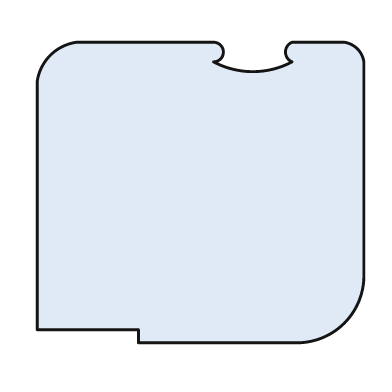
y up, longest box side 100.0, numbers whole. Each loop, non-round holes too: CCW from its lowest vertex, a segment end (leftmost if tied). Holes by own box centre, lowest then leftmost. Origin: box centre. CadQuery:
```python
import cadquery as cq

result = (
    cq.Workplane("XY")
    .moveTo(-19.0, -46.0)
    .lineTo(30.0, -46.0)
    .threePointArc((44.0, -40.0), (50.0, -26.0))
    .lineTo(50.0, 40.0)
    .threePointArc((48.0, 44.0), (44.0, 46.0))
    .lineTo(28.0, 46.0)
    .threePointArc((26.0, 43.0), (28.0, 40.0))
    .threePointArc((16.0, 37.0), (4.0, 40.0))
    .threePointArc((7.0, 43.0), (4.0, 46.0))
    .lineTo(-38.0, 46.0)
    .threePointArc((-46.0, 42.0), (-50.0, 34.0))
    .lineTo(-50.0, -42.0)
    .lineTo(-19.0, -42.0)
    .close()
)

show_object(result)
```